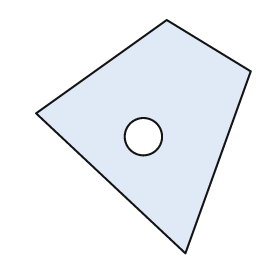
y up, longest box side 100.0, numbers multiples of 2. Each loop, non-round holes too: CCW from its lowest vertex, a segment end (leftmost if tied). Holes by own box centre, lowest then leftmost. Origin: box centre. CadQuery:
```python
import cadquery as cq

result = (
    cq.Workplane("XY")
    .moveTo(18.0, -50.0)
    .lineTo(46.0, 28.0)
    .lineTo(10.0, 50.0)
    .lineTo(-46.0, 10.0)
    .close()
    .moveTo(0.0, 0.0)
    .circle(8.0)
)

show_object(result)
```